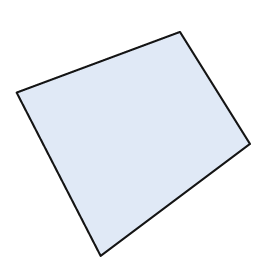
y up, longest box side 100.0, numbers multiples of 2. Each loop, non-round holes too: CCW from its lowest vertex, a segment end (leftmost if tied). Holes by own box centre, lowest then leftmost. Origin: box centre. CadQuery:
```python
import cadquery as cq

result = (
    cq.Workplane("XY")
    .moveTo(-14.0, -48.0)
    .lineTo(50.0, 0.0)
    .lineTo(20.0, 48.0)
    .lineTo(-50.0, 22.0)
    .close()
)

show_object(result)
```